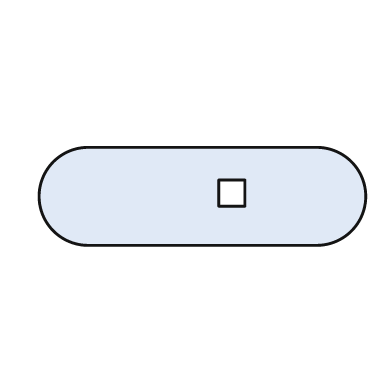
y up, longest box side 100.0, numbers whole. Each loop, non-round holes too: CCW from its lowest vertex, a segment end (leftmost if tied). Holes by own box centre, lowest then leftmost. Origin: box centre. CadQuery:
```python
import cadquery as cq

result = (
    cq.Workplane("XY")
    .moveTo(-35.0, -15.0)
    .lineTo(35.0, -15.0)
    .threePointArc((50.0, 0.0), (35.0, 15.0))
    .lineTo(-35.0, 15.0)
    .threePointArc((-50.0, 0.0), (-35.0, -15.0))
    .close()
    .moveTo(5.0, -3.0)
    .lineTo(13.0, -3.0)
    .lineTo(13.0, 5.0)
    .lineTo(5.0, 5.0)
    .close()
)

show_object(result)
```